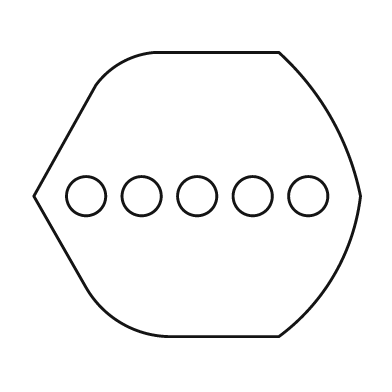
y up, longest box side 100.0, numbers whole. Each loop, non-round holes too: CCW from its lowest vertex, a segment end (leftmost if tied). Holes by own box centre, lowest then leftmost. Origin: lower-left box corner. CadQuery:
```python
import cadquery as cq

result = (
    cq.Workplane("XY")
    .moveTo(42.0, 0.0)
    .lineTo(75.0, 0.0)
    .threePointArc((92.0, 19.0), (100.0, 43.0))
    .threePointArc((91.0, 67.0), (75.0, 87.0))
    .lineTo(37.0, 87.0)
    .threePointArc((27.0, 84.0), (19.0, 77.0))
    .lineTo(0.0, 43.0)
    .lineTo(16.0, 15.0)
    .threePointArc((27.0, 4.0), (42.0, 0.0))
    .close()
    .moveTo(16.0, 43.0)
    .circle(6.0)
    .moveTo(33.0, 43.0)
    .circle(6.0)
    .moveTo(50.0, 43.0)
    .circle(6.0)
    .moveTo(67.0, 43.0)
    .circle(6.0)
    .moveTo(84.0, 43.0)
    .circle(6.0)
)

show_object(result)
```